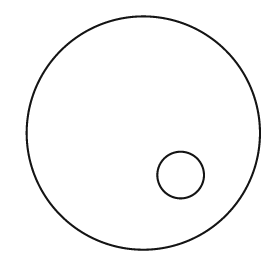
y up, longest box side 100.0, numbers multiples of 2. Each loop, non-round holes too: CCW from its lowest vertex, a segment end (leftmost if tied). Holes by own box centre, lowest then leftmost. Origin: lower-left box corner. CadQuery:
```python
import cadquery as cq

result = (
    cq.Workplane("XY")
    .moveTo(50.0, 50.0)
    .circle(50.0)
    .moveTo(66.0, 32.0)
    .circle(10.0)
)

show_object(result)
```